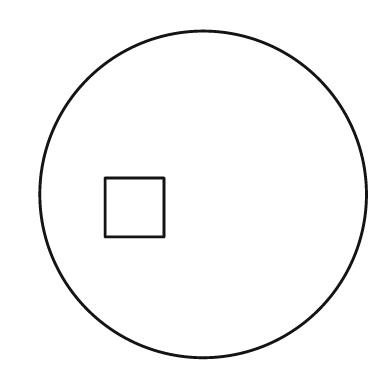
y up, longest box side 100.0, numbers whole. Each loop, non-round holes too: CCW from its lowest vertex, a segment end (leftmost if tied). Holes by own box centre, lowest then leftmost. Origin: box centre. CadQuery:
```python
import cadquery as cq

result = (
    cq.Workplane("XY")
    .moveTo(0.0, 0.0)
    .circle(50.0)
    .moveTo(-30.0, -13.0)
    .lineTo(-12.0, -13.0)
    .lineTo(-12.0, 5.0)
    .lineTo(-30.0, 5.0)
    .close()
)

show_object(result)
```